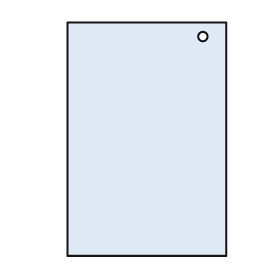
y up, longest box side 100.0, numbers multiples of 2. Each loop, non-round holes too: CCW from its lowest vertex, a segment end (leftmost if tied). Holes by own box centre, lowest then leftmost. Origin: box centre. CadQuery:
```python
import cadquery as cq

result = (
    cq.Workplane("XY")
    .moveTo(-34.0, -50.0)
    .lineTo(34.0, -50.0)
    .lineTo(34.0, 50.0)
    .lineTo(-34.0, 50.0)
    .close()
    .moveTo(24.0, 44.0)
    .circle(2.0)
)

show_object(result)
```